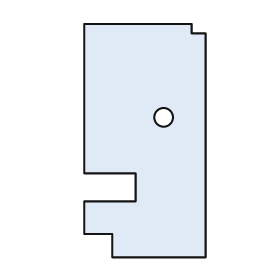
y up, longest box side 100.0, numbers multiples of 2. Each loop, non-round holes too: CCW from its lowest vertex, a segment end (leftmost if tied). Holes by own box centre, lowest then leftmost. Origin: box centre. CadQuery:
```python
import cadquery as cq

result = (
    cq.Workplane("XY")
    .moveTo(-14.0, -50.0)
    .lineTo(26.0, -50.0)
    .lineTo(26.0, 46.0)
    .lineTo(20.0, 46.0)
    .lineTo(20.0, 50.0)
    .lineTo(-26.0, 50.0)
    .lineTo(-26.0, -14.0)
    .lineTo(-4.0, -14.0)
    .lineTo(-4.0, -26.0)
    .lineTo(-26.0, -26.0)
    .lineTo(-26.0, -40.0)
    .lineTo(-14.0, -40.0)
    .close()
    .moveTo(8.0, 10.0)
    .circle(4.0)
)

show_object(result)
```